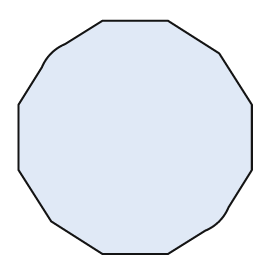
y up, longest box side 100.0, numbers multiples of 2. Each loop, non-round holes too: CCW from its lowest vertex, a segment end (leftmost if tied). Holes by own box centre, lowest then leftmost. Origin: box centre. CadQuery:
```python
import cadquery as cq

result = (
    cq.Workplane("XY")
    .moveTo(-14.0, -50.0)
    .lineTo(14.0, -50.0)
    .lineTo(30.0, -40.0)
    .threePointArc((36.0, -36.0), (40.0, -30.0))
    .lineTo(50.0, -14.0)
    .lineTo(50.0, 14.0)
    .lineTo(36.0, 36.0)
    .lineTo(14.0, 50.0)
    .lineTo(-14.0, 50.0)
    .lineTo(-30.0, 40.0)
    .threePointArc((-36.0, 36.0), (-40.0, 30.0))
    .lineTo(-50.0, 14.0)
    .lineTo(-50.0, -14.0)
    .lineTo(-36.0, -36.0)
    .close()
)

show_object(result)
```